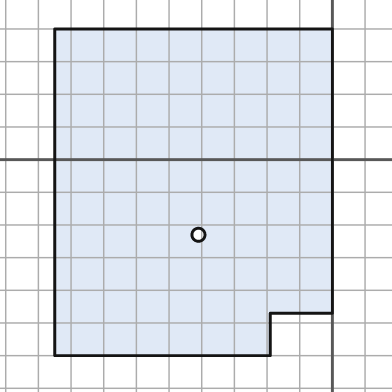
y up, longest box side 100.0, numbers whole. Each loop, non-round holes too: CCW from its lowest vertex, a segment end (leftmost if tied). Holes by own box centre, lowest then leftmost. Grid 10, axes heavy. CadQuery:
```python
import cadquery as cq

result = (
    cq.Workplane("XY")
    .moveTo(-85.0, -60.0)
    .lineTo(-19.0, -60.0)
    .lineTo(-19.0, -47.0)
    .lineTo(0.0, -47.0)
    .lineTo(0.0, 40.0)
    .lineTo(-85.0, 40.0)
    .close()
    .moveTo(-41.0, -23.0)
    .circle(2.0)
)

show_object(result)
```